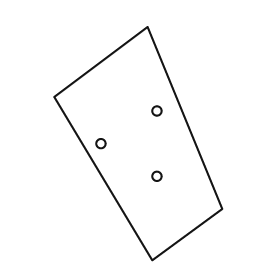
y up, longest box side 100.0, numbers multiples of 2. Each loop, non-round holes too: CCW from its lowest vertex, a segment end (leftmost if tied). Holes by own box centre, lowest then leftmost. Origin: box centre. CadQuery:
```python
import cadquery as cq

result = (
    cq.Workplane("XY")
    .moveTo(6.0, -50.0)
    .lineTo(36.0, -28.0)
    .lineTo(4.0, 50.0)
    .lineTo(-36.0, 20.0)
    .close()
    .moveTo(8.0, -14.0)
    .circle(2.0)
    .moveTo(-16.0, 0.0)
    .circle(2.0)
    .moveTo(8.0, 14.0)
    .circle(2.0)
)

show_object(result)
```